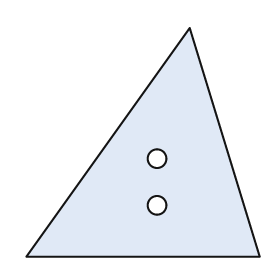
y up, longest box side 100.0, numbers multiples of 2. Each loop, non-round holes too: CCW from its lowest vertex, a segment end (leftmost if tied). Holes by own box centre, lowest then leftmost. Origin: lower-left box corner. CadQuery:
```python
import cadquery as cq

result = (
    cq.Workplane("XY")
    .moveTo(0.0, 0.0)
    .lineTo(100.0, 0.0)
    .lineTo(70.0, 98.0)
    .close()
    .moveTo(56.0, 22.0)
    .circle(4.0)
    .moveTo(56.0, 42.0)
    .circle(4.0)
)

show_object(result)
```